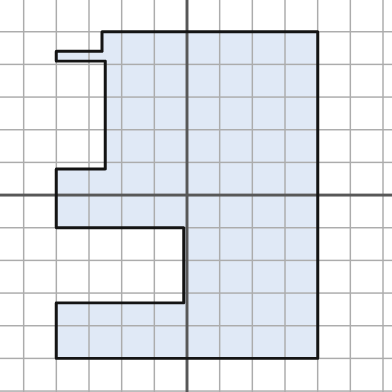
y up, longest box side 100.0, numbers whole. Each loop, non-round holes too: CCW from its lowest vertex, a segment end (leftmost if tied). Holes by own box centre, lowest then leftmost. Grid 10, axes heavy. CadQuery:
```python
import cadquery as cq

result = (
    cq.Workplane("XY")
    .moveTo(-40.0, -50.0)
    .lineTo(40.0, -50.0)
    .lineTo(40.0, 50.0)
    .lineTo(-26.0, 50.0)
    .lineTo(-26.0, 44.0)
    .lineTo(-40.0, 44.0)
    .lineTo(-40.0, 41.0)
    .lineTo(-25.0, 41.0)
    .lineTo(-25.0, 8.0)
    .lineTo(-40.0, 8.0)
    .lineTo(-40.0, -10.0)
    .lineTo(-1.0, -10.0)
    .lineTo(-1.0, -33.0)
    .lineTo(-40.0, -33.0)
    .close()
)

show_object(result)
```